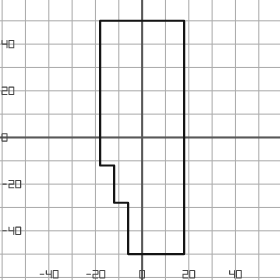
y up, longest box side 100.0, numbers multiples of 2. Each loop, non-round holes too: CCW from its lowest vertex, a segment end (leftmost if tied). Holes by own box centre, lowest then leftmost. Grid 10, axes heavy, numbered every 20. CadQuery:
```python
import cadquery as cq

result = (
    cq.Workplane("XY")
    .moveTo(-6.0, -50.0)
    .lineTo(18.0, -50.0)
    .lineTo(18.0, 50.0)
    .lineTo(-18.0, 50.0)
    .lineTo(-18.0, -12.0)
    .lineTo(-12.0, -12.0)
    .lineTo(-12.0, -28.0)
    .lineTo(-6.0, -28.0)
    .close()
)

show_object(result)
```